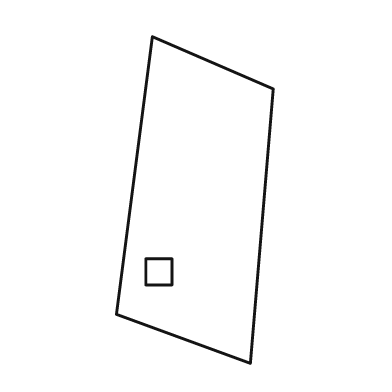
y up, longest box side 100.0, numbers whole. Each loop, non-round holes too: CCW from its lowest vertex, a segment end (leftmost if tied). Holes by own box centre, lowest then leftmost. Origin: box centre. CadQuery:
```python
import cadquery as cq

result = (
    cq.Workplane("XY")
    .moveTo(17.0, -50.0)
    .lineTo(24.0, 34.0)
    .lineTo(-13.0, 50.0)
    .lineTo(-24.0, -35.0)
    .close()
    .moveTo(-15.0, -26.0)
    .lineTo(-7.0, -26.0)
    .lineTo(-7.0, -18.0)
    .lineTo(-15.0, -18.0)
    .close()
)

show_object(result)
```